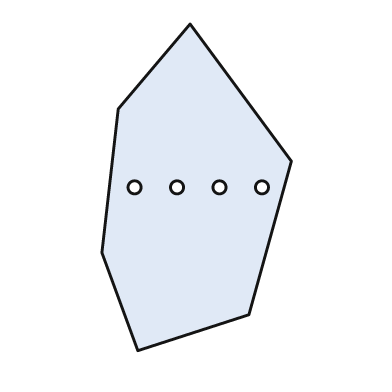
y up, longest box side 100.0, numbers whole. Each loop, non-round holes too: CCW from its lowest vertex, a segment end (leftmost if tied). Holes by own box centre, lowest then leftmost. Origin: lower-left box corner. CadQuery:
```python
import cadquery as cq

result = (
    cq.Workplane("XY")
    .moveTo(11.0, 0.0)
    .lineTo(45.0, 11.0)
    .lineTo(58.0, 58.0)
    .lineTo(27.0, 100.0)
    .lineTo(5.0, 74.0)
    .lineTo(0.0, 30.0)
    .close()
    .moveTo(10.0, 50.0)
    .circle(2.0)
    .moveTo(23.0, 50.0)
    .circle(2.0)
    .moveTo(36.0, 50.0)
    .circle(2.0)
    .moveTo(49.0, 50.0)
    .circle(2.0)
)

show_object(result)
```